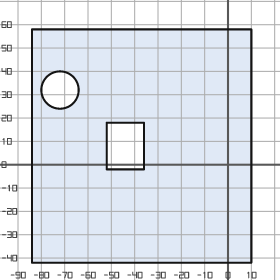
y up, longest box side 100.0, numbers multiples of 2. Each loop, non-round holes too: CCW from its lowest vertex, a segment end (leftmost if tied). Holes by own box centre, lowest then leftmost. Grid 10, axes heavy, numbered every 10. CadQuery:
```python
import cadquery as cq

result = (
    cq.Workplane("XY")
    .moveTo(-84.0, -42.0)
    .lineTo(10.0, -42.0)
    .lineTo(10.0, 58.0)
    .lineTo(-84.0, 58.0)
    .close()
    .moveTo(-52.0, -2.0)
    .lineTo(-36.0, -2.0)
    .lineTo(-36.0, 18.0)
    .lineTo(-52.0, 18.0)
    .close()
    .moveTo(-72.0, 32.0)
    .circle(8.0)
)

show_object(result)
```